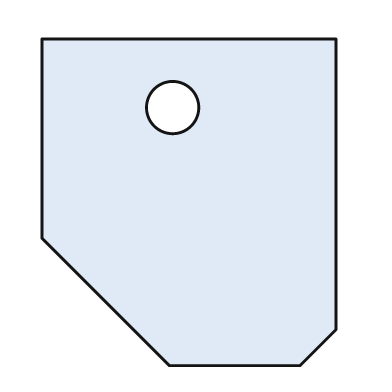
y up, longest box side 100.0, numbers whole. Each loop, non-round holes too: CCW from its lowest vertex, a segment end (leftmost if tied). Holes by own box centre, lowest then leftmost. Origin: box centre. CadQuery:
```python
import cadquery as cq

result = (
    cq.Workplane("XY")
    .moveTo(-6.0, -50.0)
    .lineTo(34.0, -50.0)
    .lineTo(45.0, -39.0)
    .lineTo(45.0, 50.0)
    .lineTo(-45.0, 50.0)
    .lineTo(-45.0, -11.0)
    .close()
    .moveTo(-5.0, 29.0)
    .circle(8.0)
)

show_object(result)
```